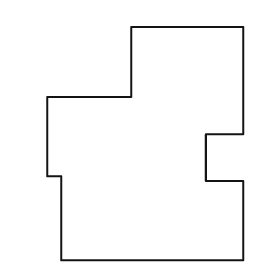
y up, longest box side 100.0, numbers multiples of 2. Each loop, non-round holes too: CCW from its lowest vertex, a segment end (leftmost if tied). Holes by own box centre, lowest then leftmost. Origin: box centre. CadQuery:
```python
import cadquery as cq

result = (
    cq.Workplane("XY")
    .moveTo(-36.0, -50.0)
    .lineTo(42.0, -50.0)
    .lineTo(42.0, -16.0)
    .lineTo(26.0, -16.0)
    .lineTo(26.0, 4.0)
    .lineTo(42.0, 4.0)
    .lineTo(42.0, 50.0)
    .lineTo(-6.0, 50.0)
    .lineTo(-6.0, 20.0)
    .lineTo(-42.0, 20.0)
    .lineTo(-42.0, -14.0)
    .lineTo(-36.0, -14.0)
    .close()
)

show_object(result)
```